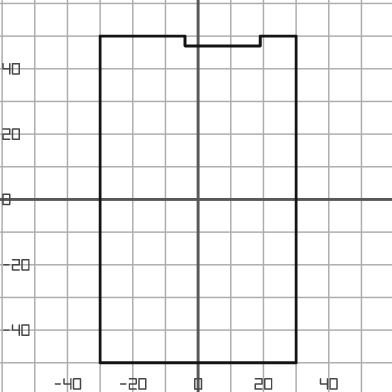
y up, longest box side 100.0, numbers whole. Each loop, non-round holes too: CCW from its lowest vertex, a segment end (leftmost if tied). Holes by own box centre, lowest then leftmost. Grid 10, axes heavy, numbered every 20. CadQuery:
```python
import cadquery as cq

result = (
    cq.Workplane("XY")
    .moveTo(-30.0, -50.0)
    .lineTo(30.0, -50.0)
    .lineTo(30.0, 50.0)
    .lineTo(19.0, 50.0)
    .lineTo(19.0, 47.0)
    .lineTo(-4.0, 47.0)
    .lineTo(-4.0, 50.0)
    .lineTo(-30.0, 50.0)
    .close()
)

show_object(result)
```